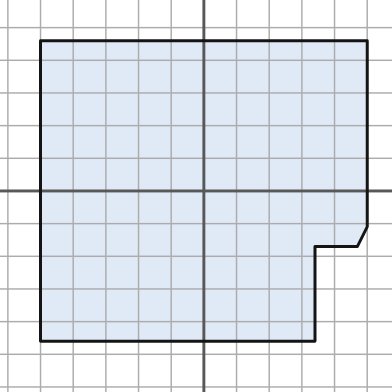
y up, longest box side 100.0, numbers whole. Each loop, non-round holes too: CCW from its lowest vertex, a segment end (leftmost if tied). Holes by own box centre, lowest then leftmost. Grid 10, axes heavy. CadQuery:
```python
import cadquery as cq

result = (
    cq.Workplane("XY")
    .moveTo(-50.0, -46.0)
    .lineTo(34.0, -46.0)
    .lineTo(34.0, -17.0)
    .lineTo(47.0, -17.0)
    .lineTo(50.0, -11.0)
    .lineTo(50.0, 46.0)
    .lineTo(-50.0, 46.0)
    .close()
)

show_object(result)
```